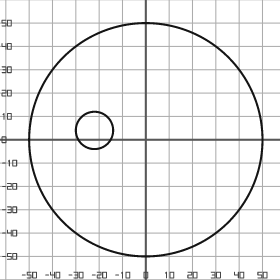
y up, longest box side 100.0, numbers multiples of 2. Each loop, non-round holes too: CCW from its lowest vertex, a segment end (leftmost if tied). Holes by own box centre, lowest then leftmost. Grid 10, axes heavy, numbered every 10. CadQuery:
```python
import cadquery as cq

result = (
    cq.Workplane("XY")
    .moveTo(0.0, 0.0)
    .circle(50.0)
    .moveTo(-22.0, 4.0)
    .circle(8.0)
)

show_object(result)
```